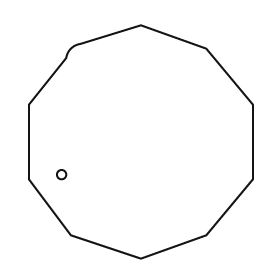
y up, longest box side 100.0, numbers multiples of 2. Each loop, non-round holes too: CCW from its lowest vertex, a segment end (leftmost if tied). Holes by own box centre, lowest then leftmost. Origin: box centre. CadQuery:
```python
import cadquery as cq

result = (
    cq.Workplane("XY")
    .moveTo(0.0, -50.0)
    .lineTo(28.0, -40.0)
    .lineTo(48.0, -16.0)
    .lineTo(48.0, 16.0)
    .lineTo(28.0, 40.0)
    .lineTo(0.0, 50.0)
    .lineTo(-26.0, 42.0)
    .threePointArc((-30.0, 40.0), (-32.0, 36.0))
    .lineTo(-48.0, 16.0)
    .lineTo(-48.0, -16.0)
    .lineTo(-30.0, -40.0)
    .close()
    .moveTo(-34.0, -14.0)
    .circle(2.0)
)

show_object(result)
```